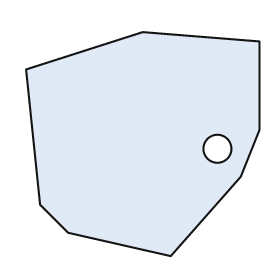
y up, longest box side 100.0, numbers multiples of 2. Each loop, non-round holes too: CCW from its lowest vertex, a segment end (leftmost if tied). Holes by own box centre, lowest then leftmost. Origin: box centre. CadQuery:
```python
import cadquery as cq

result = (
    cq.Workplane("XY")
    .moveTo(12.0, -48.0)
    .lineTo(42.0, -14.0)
    .lineTo(50.0, 6.0)
    .lineTo(50.0, 44.0)
    .lineTo(0.0, 48.0)
    .lineTo(-50.0, 32.0)
    .lineTo(-44.0, -26.0)
    .lineTo(-32.0, -38.0)
    .close()
    .moveTo(32.0, -2.0)
    .circle(6.0)
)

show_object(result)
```